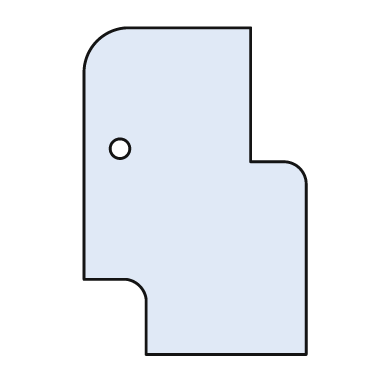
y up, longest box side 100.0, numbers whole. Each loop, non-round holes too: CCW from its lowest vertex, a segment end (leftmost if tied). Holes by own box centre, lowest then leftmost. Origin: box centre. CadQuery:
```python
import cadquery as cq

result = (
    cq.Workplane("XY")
    .moveTo(-15.0, -50.0)
    .lineTo(34.0, -50.0)
    .lineTo(34.0, 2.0)
    .threePointArc((32.0, 7.0), (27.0, 9.0))
    .lineTo(17.0, 9.0)
    .lineTo(17.0, 50.0)
    .lineTo(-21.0, 50.0)
    .threePointArc((-30.0, 46.0), (-34.0, 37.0))
    .lineTo(-34.0, -27.0)
    .lineTo(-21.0, -27.0)
    .threePointArc((-17.0, -29.0), (-15.0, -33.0))
    .close()
    .moveTo(-23.0, 13.0)
    .circle(3.0)
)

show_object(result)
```